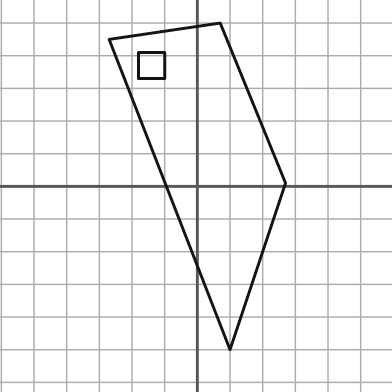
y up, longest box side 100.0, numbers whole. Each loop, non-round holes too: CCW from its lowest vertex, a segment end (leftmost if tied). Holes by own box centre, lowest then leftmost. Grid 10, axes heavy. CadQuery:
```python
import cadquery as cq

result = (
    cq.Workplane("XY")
    .moveTo(10.0, -50.0)
    .lineTo(27.0, 1.0)
    .lineTo(7.0, 50.0)
    .lineTo(-27.0, 45.0)
    .close()
    .moveTo(-18.0, 33.0)
    .lineTo(-10.0, 33.0)
    .lineTo(-10.0, 41.0)
    .lineTo(-18.0, 41.0)
    .close()
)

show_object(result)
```